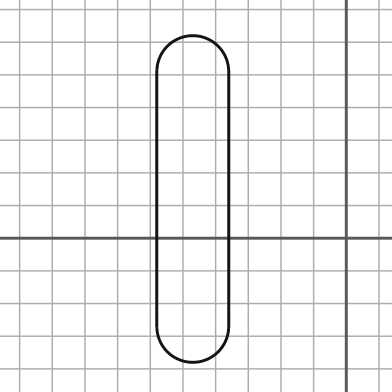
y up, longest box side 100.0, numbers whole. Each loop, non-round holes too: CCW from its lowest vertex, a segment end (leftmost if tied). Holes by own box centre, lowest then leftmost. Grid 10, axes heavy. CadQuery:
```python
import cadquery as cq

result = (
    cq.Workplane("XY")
    .moveTo(-58.0, -27.0)
    .threePointArc((-47.0, -38.0), (-36.0, -27.0))
    .lineTo(-36.0, 51.0)
    .threePointArc((-47.0, 62.0), (-58.0, 51.0))
    .close()
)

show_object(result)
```